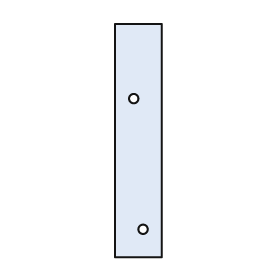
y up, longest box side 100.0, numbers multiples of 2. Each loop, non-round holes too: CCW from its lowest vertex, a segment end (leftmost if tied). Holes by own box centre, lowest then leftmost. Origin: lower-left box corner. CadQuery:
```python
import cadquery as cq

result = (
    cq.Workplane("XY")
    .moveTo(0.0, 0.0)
    .lineTo(20.0, 0.0)
    .lineTo(20.0, 100.0)
    .lineTo(0.0, 100.0)
    .close()
    .moveTo(12.0, 12.0)
    .circle(2.0)
    .moveTo(8.0, 68.0)
    .circle(2.0)
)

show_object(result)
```